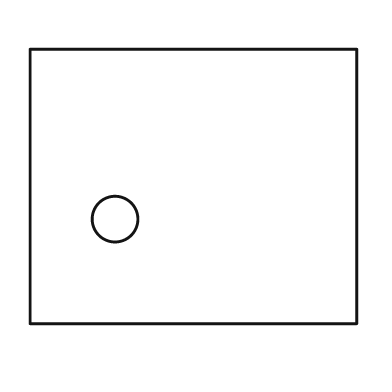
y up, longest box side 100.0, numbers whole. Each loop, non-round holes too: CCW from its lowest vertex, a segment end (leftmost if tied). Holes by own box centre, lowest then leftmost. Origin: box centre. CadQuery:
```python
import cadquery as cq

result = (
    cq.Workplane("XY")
    .moveTo(-50.0, -42.0)
    .lineTo(50.0, -42.0)
    .lineTo(50.0, 42.0)
    .lineTo(-50.0, 42.0)
    .close()
    .moveTo(-24.0, -10.0)
    .circle(7.0)
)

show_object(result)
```